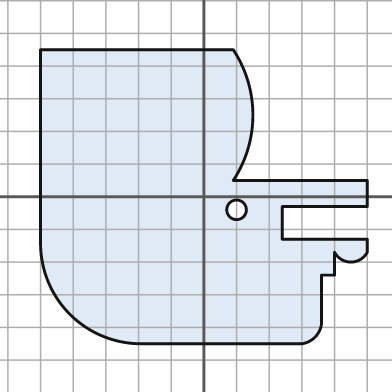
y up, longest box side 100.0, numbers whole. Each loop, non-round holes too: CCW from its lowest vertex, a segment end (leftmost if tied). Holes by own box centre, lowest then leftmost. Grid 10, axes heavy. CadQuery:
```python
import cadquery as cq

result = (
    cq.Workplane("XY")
    .moveTo(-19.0, -45.0)
    .lineTo(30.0, -45.0)
    .threePointArc((34.0, -43.0), (36.0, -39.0))
    .lineTo(36.0, -24.0)
    .lineTo(40.0, -24.0)
    .lineTo(40.0, -17.0)
    .threePointArc((45.0, -20.0), (50.0, -17.0))
    .lineTo(50.0, -13.0)
    .lineTo(24.0, -13.0)
    .lineTo(24.0, -3.0)
    .lineTo(50.0, -3.0)
    .lineTo(50.0, 5.0)
    .lineTo(9.0, 5.0)
    .threePointArc((15.0, 25.0), (9.0, 45.0))
    .lineTo(-50.0, 45.0)
    .lineTo(-50.0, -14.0)
    .threePointArc((-41.0, -36.0), (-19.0, -45.0))
    .close()
    .moveTo(10.0, -4.0)
    .circle(3.0)
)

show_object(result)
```